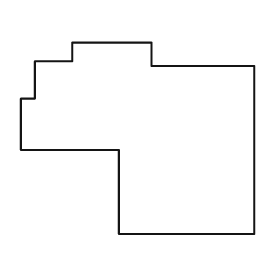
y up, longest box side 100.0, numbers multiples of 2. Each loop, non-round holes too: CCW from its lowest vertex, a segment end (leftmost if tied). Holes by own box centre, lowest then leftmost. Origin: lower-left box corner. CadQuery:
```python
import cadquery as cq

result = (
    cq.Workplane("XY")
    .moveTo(42.0, 0.0)
    .lineTo(100.0, 0.0)
    .lineTo(100.0, 72.0)
    .lineTo(56.0, 72.0)
    .lineTo(56.0, 82.0)
    .lineTo(22.0, 82.0)
    .lineTo(22.0, 74.0)
    .lineTo(6.0, 74.0)
    .lineTo(6.0, 58.0)
    .lineTo(0.0, 58.0)
    .lineTo(0.0, 36.0)
    .lineTo(42.0, 36.0)
    .close()
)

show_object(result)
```